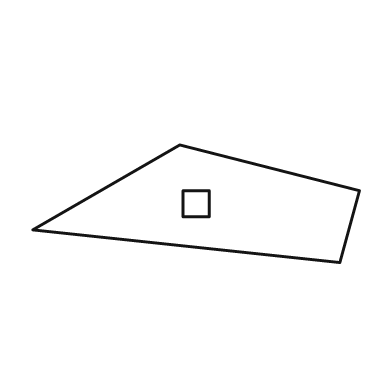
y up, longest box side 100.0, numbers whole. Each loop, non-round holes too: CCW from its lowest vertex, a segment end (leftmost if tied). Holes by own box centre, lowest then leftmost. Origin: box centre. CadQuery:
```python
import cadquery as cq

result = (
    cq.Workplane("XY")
    .moveTo(44.0, -18.0)
    .lineTo(50.0, 4.0)
    .lineTo(-5.0, 18.0)
    .lineTo(-50.0, -8.0)
    .close()
    .moveTo(-4.0, -4.0)
    .lineTo(4.0, -4.0)
    .lineTo(4.0, 4.0)
    .lineTo(-4.0, 4.0)
    .close()
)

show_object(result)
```